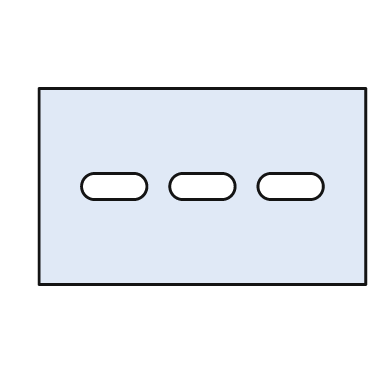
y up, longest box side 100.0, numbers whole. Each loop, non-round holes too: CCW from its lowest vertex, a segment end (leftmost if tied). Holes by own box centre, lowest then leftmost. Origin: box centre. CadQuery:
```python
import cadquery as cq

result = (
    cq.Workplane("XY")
    .moveTo(-50.0, -30.0)
    .lineTo(50.0, -30.0)
    .lineTo(50.0, 30.0)
    .lineTo(-50.0, 30.0)
    .close()
    .moveTo(-33.0, -4.0)
    .lineTo(-21.0, -4.0)
    .threePointArc((-17.0, 0.0), (-21.0, 4.0))
    .lineTo(-33.0, 4.0)
    .threePointArc((-37.0, 0.0), (-33.0, -4.0))
    .close()
    .moveTo(-6.0, -4.0)
    .lineTo(6.0, -4.0)
    .threePointArc((10.0, 0.0), (6.0, 4.0))
    .lineTo(-6.0, 4.0)
    .threePointArc((-10.0, 0.0), (-6.0, -4.0))
    .close()
    .moveTo(21.0, -4.0)
    .lineTo(33.0, -4.0)
    .threePointArc((37.0, 0.0), (33.0, 4.0))
    .lineTo(21.0, 4.0)
    .threePointArc((17.0, 0.0), (21.0, -4.0))
    .close()
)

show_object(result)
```